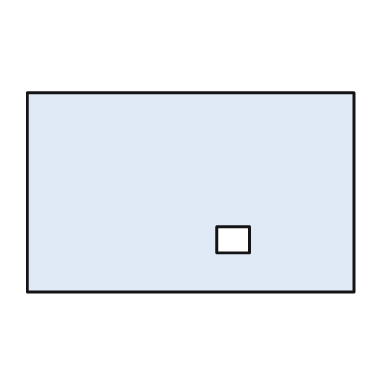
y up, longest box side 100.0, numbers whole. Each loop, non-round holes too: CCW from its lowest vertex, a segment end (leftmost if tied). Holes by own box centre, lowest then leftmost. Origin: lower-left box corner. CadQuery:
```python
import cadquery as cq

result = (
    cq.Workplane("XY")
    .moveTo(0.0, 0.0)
    .lineTo(100.0, 0.0)
    .lineTo(100.0, 61.0)
    .lineTo(0.0, 61.0)
    .close()
    .moveTo(58.0, 12.0)
    .lineTo(68.0, 12.0)
    .lineTo(68.0, 20.0)
    .lineTo(58.0, 20.0)
    .close()
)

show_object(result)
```